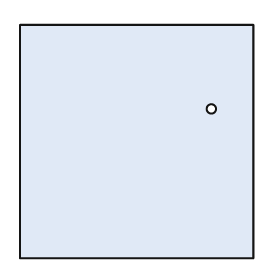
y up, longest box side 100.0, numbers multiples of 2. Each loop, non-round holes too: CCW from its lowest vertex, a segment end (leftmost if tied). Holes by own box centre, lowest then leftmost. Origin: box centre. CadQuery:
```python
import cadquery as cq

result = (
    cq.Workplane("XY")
    .moveTo(-50.0, -50.0)
    .lineTo(50.0, -50.0)
    .lineTo(50.0, 50.0)
    .lineTo(-50.0, 50.0)
    .close()
    .moveTo(32.0, 14.0)
    .circle(2.0)
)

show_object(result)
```